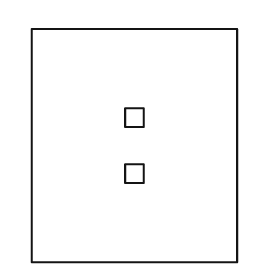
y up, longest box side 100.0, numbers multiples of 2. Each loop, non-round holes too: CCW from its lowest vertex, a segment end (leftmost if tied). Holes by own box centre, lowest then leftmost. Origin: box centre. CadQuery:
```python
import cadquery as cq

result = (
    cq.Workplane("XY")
    .moveTo(-44.0, -50.0)
    .lineTo(44.0, -50.0)
    .lineTo(44.0, 50.0)
    .lineTo(-44.0, 50.0)
    .close()
    .moveTo(-4.0, -16.0)
    .lineTo(4.0, -16.0)
    .lineTo(4.0, -8.0)
    .lineTo(-4.0, -8.0)
    .close()
    .moveTo(-4.0, 8.0)
    .lineTo(4.0, 8.0)
    .lineTo(4.0, 16.0)
    .lineTo(-4.0, 16.0)
    .close()
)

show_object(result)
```